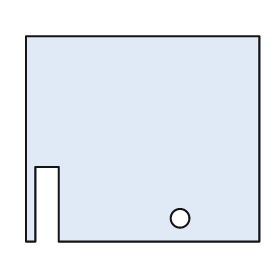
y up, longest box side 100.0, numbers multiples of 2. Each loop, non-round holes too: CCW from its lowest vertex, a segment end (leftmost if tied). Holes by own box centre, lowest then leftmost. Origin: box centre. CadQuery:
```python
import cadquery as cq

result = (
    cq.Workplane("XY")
    .moveTo(-50.0, -44.0)
    .lineTo(-46.0, -44.0)
    .lineTo(-46.0, -12.0)
    .lineTo(-36.0, -12.0)
    .lineTo(-36.0, -44.0)
    .lineTo(50.0, -44.0)
    .lineTo(50.0, 44.0)
    .lineTo(-50.0, 44.0)
    .close()
    .moveTo(16.0, -34.0)
    .circle(4.0)
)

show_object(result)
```